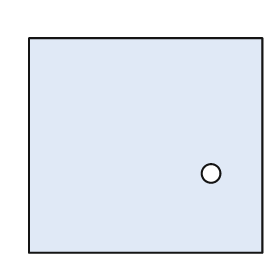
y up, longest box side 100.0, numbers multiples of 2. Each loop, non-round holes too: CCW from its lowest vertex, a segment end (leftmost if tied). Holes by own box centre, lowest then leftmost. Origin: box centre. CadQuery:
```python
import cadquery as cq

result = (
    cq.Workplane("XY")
    .moveTo(-50.0, -46.0)
    .lineTo(50.0, -46.0)
    .lineTo(50.0, 46.0)
    .lineTo(-50.0, 46.0)
    .close()
    .moveTo(28.0, -12.0)
    .circle(4.0)
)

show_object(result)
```